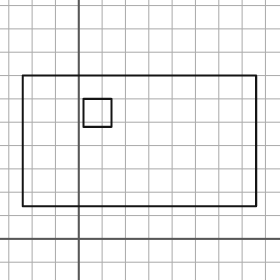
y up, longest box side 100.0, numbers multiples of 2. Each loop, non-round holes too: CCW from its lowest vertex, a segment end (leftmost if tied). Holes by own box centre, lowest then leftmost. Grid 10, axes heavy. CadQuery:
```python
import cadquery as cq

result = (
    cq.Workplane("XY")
    .moveTo(-24.0, 14.0)
    .lineTo(76.0, 14.0)
    .lineTo(76.0, 70.0)
    .lineTo(-24.0, 70.0)
    .close()
    .moveTo(2.0, 48.0)
    .lineTo(14.0, 48.0)
    .lineTo(14.0, 60.0)
    .lineTo(2.0, 60.0)
    .close()
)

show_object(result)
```